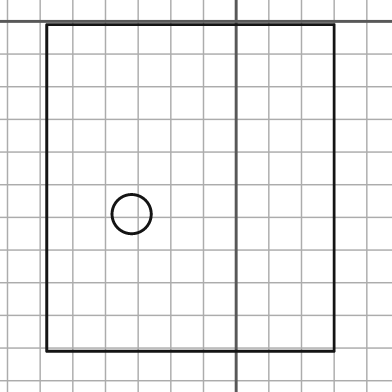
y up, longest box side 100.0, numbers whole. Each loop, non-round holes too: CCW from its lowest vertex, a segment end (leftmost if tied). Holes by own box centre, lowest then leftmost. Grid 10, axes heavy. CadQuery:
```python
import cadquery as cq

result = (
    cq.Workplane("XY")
    .moveTo(-58.0, -101.0)
    .lineTo(30.0, -101.0)
    .lineTo(30.0, -1.0)
    .lineTo(-58.0, -1.0)
    .close()
    .moveTo(-32.0, -59.0)
    .circle(6.0)
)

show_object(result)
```